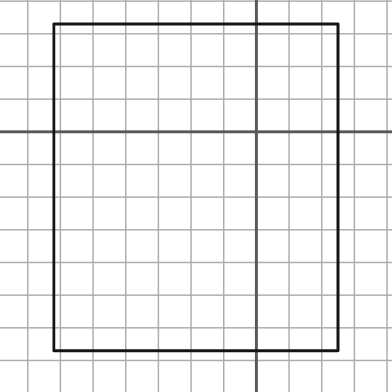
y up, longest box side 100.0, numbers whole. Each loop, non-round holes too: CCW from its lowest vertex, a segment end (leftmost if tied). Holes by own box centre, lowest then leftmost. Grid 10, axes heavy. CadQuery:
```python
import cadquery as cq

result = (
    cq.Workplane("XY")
    .moveTo(-62.0, -67.0)
    .lineTo(25.0, -67.0)
    .lineTo(25.0, 33.0)
    .lineTo(-62.0, 33.0)
    .close()
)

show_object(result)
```